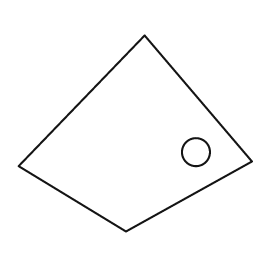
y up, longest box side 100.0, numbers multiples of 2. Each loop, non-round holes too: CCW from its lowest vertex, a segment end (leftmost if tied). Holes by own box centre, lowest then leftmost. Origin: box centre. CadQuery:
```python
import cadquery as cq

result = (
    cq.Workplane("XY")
    .moveTo(-4.0, -42.0)
    .lineTo(50.0, -12.0)
    .lineTo(4.0, 42.0)
    .lineTo(-50.0, -14.0)
    .close()
    .moveTo(26.0, -8.0)
    .circle(6.0)
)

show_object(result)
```